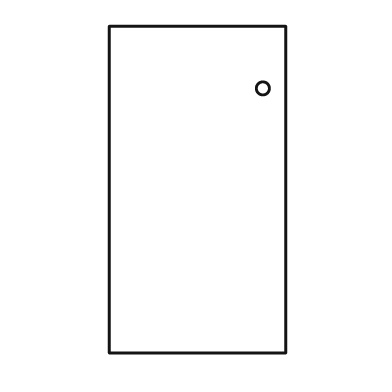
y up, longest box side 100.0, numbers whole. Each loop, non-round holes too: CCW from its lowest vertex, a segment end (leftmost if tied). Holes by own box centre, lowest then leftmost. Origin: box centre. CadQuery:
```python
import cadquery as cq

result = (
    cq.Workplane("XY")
    .moveTo(-27.0, -50.0)
    .lineTo(27.0, -50.0)
    .lineTo(27.0, 50.0)
    .lineTo(-27.0, 50.0)
    .close()
    .moveTo(20.0, 31.0)
    .circle(2.0)
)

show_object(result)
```